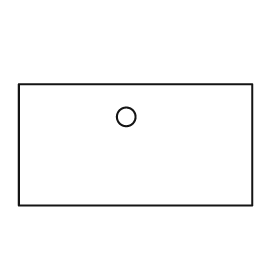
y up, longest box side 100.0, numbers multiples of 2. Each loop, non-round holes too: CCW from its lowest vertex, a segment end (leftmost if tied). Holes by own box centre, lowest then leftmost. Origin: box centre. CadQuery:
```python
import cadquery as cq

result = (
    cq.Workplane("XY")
    .moveTo(-50.0, -26.0)
    .lineTo(50.0, -26.0)
    .lineTo(50.0, 26.0)
    .lineTo(-50.0, 26.0)
    .close()
    .moveTo(-4.0, 12.0)
    .circle(4.0)
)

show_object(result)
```